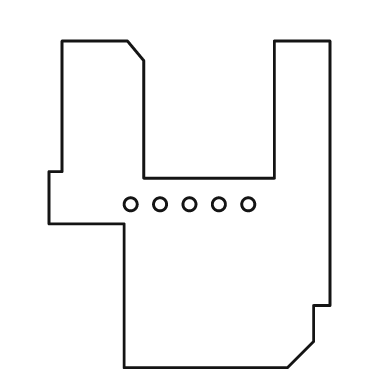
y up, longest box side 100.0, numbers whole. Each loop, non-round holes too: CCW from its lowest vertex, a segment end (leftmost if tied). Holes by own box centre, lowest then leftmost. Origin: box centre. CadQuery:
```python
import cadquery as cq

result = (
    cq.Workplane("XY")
    .moveTo(-20.0, -50.0)
    .lineTo(30.0, -50.0)
    .lineTo(38.0, -42.0)
    .lineTo(38.0, -31.0)
    .lineTo(43.0, -31.0)
    .lineTo(43.0, 50.0)
    .lineTo(26.0, 50.0)
    .lineTo(26.0, 8.0)
    .lineTo(-14.0, 8.0)
    .lineTo(-14.0, 44.0)
    .lineTo(-19.0, 50.0)
    .lineTo(-39.0, 50.0)
    .lineTo(-39.0, 10.0)
    .lineTo(-43.0, 10.0)
    .lineTo(-43.0, -6.0)
    .lineTo(-20.0, -6.0)
    .close()
    .moveTo(-18.0, 0.0)
    .circle(2.0)
    .moveTo(-9.0, 0.0)
    .circle(2.0)
    .moveTo(0.0, 0.0)
    .circle(2.0)
    .moveTo(9.0, 0.0)
    .circle(2.0)
    .moveTo(18.0, 0.0)
    .circle(2.0)
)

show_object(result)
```